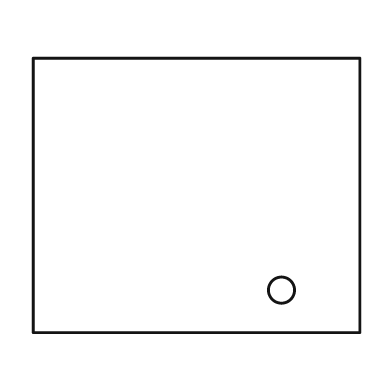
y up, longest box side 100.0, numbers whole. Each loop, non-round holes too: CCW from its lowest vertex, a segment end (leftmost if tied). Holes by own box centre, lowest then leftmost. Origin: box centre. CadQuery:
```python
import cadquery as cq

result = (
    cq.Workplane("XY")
    .moveTo(-50.0, -42.0)
    .lineTo(50.0, -42.0)
    .lineTo(50.0, 42.0)
    .lineTo(-50.0, 42.0)
    .close()
    .moveTo(26.0, -29.0)
    .circle(4.0)
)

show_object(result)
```